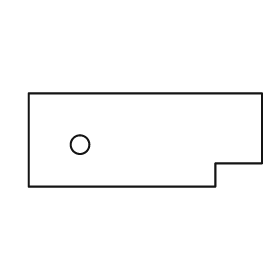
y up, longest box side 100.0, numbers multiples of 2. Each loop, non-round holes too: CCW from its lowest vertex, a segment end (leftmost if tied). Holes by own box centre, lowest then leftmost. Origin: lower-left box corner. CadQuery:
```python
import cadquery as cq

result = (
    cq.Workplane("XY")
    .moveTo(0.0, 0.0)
    .lineTo(80.0, 0.0)
    .lineTo(80.0, 10.0)
    .lineTo(100.0, 10.0)
    .lineTo(100.0, 40.0)
    .lineTo(0.0, 40.0)
    .close()
    .moveTo(22.0, 18.0)
    .circle(4.0)
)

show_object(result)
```